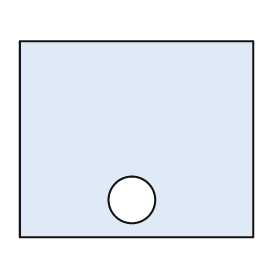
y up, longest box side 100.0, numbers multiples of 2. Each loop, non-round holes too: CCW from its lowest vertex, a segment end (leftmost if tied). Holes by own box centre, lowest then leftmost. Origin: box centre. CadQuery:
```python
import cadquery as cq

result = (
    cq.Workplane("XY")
    .moveTo(-50.0, -42.0)
    .lineTo(50.0, -42.0)
    .lineTo(50.0, 42.0)
    .lineTo(-50.0, 42.0)
    .close()
    .moveTo(-2.0, -26.0)
    .circle(10.0)
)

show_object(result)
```